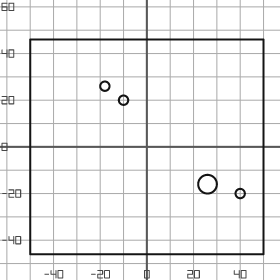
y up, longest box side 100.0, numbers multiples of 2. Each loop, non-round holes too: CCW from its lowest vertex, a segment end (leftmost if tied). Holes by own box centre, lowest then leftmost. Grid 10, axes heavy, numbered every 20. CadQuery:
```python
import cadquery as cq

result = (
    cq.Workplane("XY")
    .moveTo(-50.0, -46.0)
    .lineTo(50.0, -46.0)
    .lineTo(50.0, 46.0)
    .lineTo(-50.0, 46.0)
    .close()
    .moveTo(40.0, -20.0)
    .circle(2.0)
    .moveTo(26.0, -16.0)
    .circle(4.0)
    .moveTo(-10.0, 20.0)
    .circle(2.0)
    .moveTo(-18.0, 26.0)
    .circle(2.0)
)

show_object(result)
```